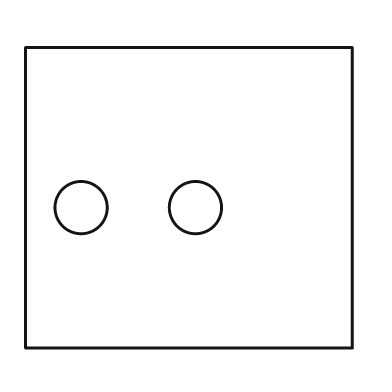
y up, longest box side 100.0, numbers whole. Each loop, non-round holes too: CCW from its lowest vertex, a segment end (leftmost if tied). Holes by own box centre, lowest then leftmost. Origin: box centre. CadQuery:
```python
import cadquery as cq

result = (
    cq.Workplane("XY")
    .moveTo(-50.0, -46.0)
    .lineTo(50.0, -46.0)
    .lineTo(50.0, 46.0)
    .lineTo(-50.0, 46.0)
    .close()
    .moveTo(-33.0, -3.0)
    .circle(8.0)
    .moveTo(2.0, -3.0)
    .circle(8.0)
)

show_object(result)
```